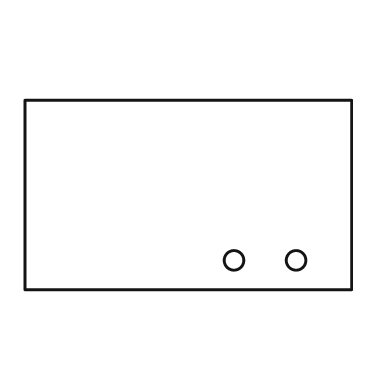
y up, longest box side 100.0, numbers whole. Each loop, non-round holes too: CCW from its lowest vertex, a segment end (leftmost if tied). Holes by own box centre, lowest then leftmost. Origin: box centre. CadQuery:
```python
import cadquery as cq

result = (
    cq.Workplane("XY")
    .moveTo(-50.0, -29.0)
    .lineTo(50.0, -29.0)
    .lineTo(50.0, 29.0)
    .lineTo(-50.0, 29.0)
    .close()
    .moveTo(14.0, -20.0)
    .circle(3.0)
    .moveTo(33.0, -20.0)
    .circle(3.0)
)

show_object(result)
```